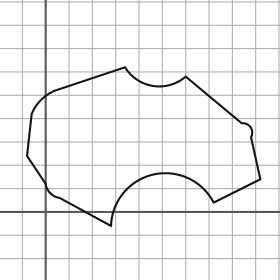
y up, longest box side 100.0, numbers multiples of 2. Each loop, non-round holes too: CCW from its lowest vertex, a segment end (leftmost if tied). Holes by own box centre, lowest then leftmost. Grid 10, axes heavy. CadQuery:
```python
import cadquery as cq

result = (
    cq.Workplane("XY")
    .moveTo(28.0, -6.0)
    .threePointArc((46.0, 16.0), (72.0, 4.0))
    .lineTo(92.0, 14.0)
    .lineTo(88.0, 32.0)
    .threePointArc((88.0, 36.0), (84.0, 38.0))
    .lineTo(60.0, 58.0)
    .threePointArc((46.0, 54.0), (34.0, 62.0))
    .lineTo(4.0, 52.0)
    .threePointArc((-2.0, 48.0), (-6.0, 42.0))
    .lineTo(-8.0, 24.0)
    .lineTo(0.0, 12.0)
    .threePointArc((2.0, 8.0), (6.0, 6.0))
    .close()
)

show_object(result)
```